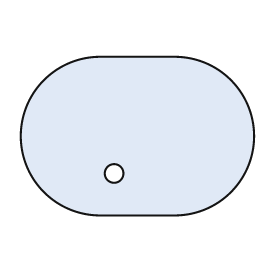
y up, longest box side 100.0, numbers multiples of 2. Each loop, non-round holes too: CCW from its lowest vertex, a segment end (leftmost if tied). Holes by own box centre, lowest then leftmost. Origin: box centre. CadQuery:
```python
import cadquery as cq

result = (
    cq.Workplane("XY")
    .moveTo(-16.0, -34.0)
    .lineTo(16.0, -34.0)
    .threePointArc((50.0, 0.0), (16.0, 34.0))
    .lineTo(-16.0, 34.0)
    .threePointArc((-50.0, 0.0), (-16.0, -34.0))
    .close()
    .moveTo(-10.0, -16.0)
    .circle(4.0)
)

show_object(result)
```